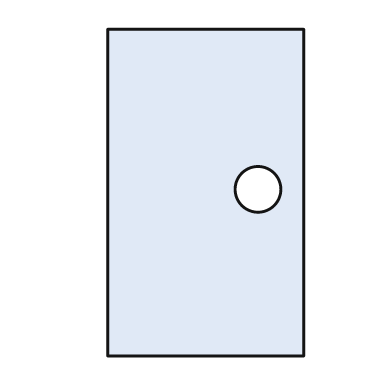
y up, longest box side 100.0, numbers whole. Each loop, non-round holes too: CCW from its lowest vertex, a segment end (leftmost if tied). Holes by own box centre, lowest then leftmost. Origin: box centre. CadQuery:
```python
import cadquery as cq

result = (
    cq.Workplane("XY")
    .moveTo(-30.0, -50.0)
    .lineTo(30.0, -50.0)
    .lineTo(30.0, 50.0)
    .lineTo(-30.0, 50.0)
    .close()
    .moveTo(16.0, 1.0)
    .circle(7.0)
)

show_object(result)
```